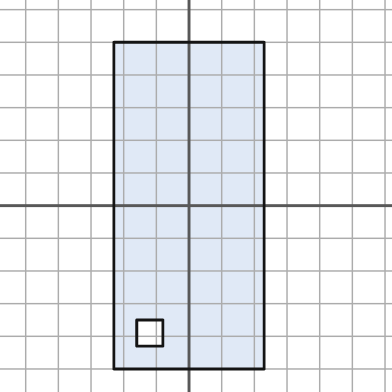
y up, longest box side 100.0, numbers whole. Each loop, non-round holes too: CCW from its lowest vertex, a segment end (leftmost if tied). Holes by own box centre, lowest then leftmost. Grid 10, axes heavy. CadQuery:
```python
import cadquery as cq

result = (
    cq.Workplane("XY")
    .moveTo(-23.0, -50.0)
    .lineTo(23.0, -50.0)
    .lineTo(23.0, 50.0)
    .lineTo(-23.0, 50.0)
    .close()
    .moveTo(-16.0, -43.0)
    .lineTo(-8.0, -43.0)
    .lineTo(-8.0, -35.0)
    .lineTo(-16.0, -35.0)
    .close()
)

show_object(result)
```